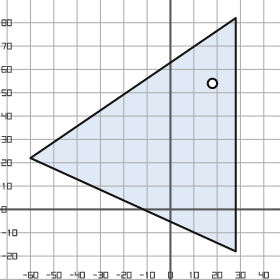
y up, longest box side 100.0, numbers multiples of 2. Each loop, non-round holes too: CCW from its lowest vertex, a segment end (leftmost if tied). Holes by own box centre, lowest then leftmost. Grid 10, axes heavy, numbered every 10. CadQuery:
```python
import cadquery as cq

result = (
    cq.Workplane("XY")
    .moveTo(28.0, -18.0)
    .lineTo(28.0, 82.0)
    .lineTo(-60.0, 22.0)
    .close()
    .moveTo(18.0, 54.0)
    .circle(2.0)
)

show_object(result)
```